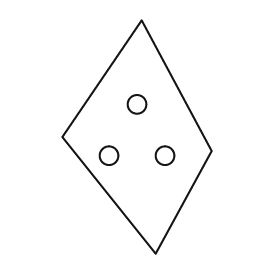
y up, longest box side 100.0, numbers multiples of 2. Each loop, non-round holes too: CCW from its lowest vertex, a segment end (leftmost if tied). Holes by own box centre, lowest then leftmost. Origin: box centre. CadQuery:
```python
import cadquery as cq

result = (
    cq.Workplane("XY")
    .moveTo(8.0, -50.0)
    .lineTo(32.0, -6.0)
    .lineTo(2.0, 50.0)
    .lineTo(-32.0, 0.0)
    .close()
    .moveTo(-12.0, -8.0)
    .circle(4.0)
    .moveTo(12.0, -8.0)
    .circle(4.0)
    .moveTo(0.0, 14.0)
    .circle(4.0)
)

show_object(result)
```